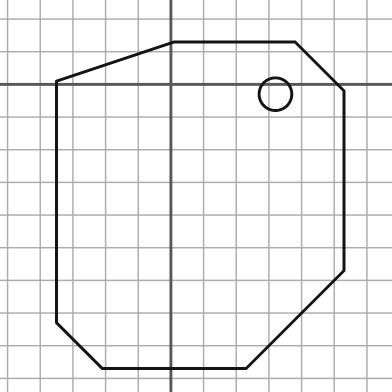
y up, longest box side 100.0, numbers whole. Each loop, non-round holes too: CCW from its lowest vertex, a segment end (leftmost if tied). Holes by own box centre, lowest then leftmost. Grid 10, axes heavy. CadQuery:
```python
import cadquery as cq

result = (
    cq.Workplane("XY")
    .moveTo(-21.0, -87.0)
    .lineTo(23.0, -87.0)
    .lineTo(53.0, -57.0)
    .lineTo(53.0, -2.0)
    .lineTo(38.0, 13.0)
    .lineTo(1.0, 13.0)
    .lineTo(-35.0, 1.0)
    .lineTo(-35.0, -73.0)
    .close()
    .moveTo(32.0, -3.0)
    .circle(5.0)
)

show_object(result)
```